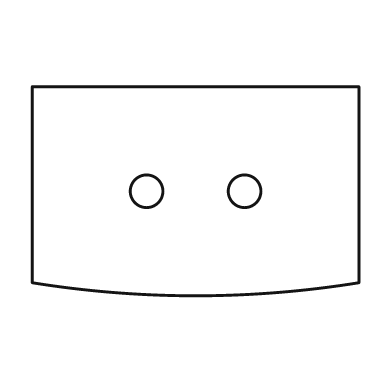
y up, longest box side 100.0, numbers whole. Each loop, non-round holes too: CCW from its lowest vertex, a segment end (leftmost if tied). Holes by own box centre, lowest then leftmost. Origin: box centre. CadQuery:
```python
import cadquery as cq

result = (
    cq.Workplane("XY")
    .moveTo(-50.0, -28.0)
    .threePointArc((0.0, -32.0), (50.0, -28.0))
    .lineTo(50.0, 32.0)
    .lineTo(-50.0, 32.0)
    .close()
    .moveTo(-15.0, 0.0)
    .circle(5.0)
    .moveTo(15.0, 0.0)
    .circle(5.0)
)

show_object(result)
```